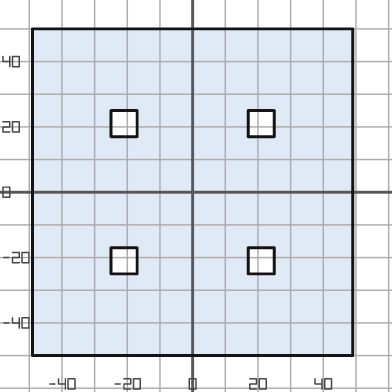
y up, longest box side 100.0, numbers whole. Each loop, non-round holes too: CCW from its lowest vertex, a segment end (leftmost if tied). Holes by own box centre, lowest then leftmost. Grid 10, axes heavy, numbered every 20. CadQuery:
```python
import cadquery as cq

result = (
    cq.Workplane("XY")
    .moveTo(-49.0, -50.0)
    .lineTo(49.0, -50.0)
    .lineTo(49.0, 50.0)
    .lineTo(-49.0, 50.0)
    .close()
    .moveTo(-25.0, -25.0)
    .lineTo(-17.0, -25.0)
    .lineTo(-17.0, -17.0)
    .lineTo(-25.0, -17.0)
    .close()
    .moveTo(17.0, -25.0)
    .lineTo(25.0, -25.0)
    .lineTo(25.0, -17.0)
    .lineTo(17.0, -17.0)
    .close()
    .moveTo(-25.0, 17.0)
    .lineTo(-17.0, 17.0)
    .lineTo(-17.0, 25.0)
    .lineTo(-25.0, 25.0)
    .close()
    .moveTo(17.0, 17.0)
    .lineTo(25.0, 17.0)
    .lineTo(25.0, 25.0)
    .lineTo(17.0, 25.0)
    .close()
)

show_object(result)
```